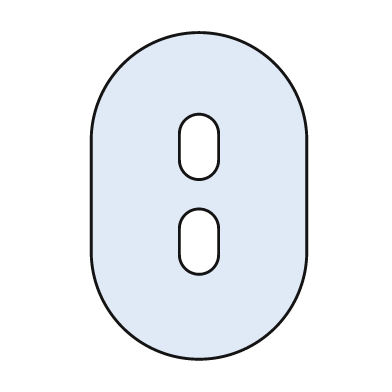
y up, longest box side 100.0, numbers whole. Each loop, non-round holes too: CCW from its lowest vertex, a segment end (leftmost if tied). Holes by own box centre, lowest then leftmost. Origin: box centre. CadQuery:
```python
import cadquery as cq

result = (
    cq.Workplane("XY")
    .moveTo(-33.0, -17.0)
    .threePointArc((0.0, -50.0), (33.0, -17.0))
    .lineTo(33.0, 17.0)
    .threePointArc((0.0, 50.0), (-33.0, 17.0))
    .close()
    .moveTo(-6.0, -18.0)
    .threePointArc((0.0, -24.0), (6.0, -18.0))
    .lineTo(6.0, -10.0)
    .threePointArc((0.0, -4.0), (-6.0, -10.0))
    .close()
    .moveTo(-6.0, 11.0)
    .threePointArc((0.0, 5.0), (6.0, 11.0))
    .lineTo(6.0, 19.0)
    .threePointArc((0.0, 25.0), (-6.0, 19.0))
    .close()
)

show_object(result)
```